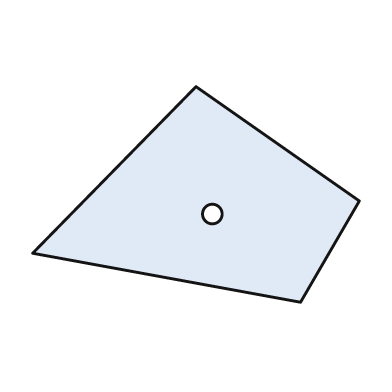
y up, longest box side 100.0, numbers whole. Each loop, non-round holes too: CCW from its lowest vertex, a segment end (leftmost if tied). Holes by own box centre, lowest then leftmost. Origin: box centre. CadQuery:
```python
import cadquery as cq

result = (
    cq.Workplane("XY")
    .moveTo(32.0, -33.0)
    .lineTo(50.0, -2.0)
    .lineTo(0.0, 33.0)
    .lineTo(-50.0, -18.0)
    .close()
    .moveTo(5.0, -6.0)
    .circle(3.0)
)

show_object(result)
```